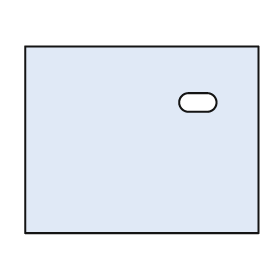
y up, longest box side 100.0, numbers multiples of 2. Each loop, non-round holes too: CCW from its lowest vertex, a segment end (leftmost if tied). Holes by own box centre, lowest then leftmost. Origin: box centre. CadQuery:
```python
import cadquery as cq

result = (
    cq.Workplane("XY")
    .moveTo(-50.0, -40.0)
    .lineTo(50.0, -40.0)
    .lineTo(50.0, 40.0)
    .lineTo(-50.0, 40.0)
    .close()
    .moveTo(20.0, 12.0)
    .lineTo(28.0, 12.0)
    .threePointArc((32.0, 16.0), (28.0, 20.0))
    .lineTo(20.0, 20.0)
    .threePointArc((16.0, 16.0), (20.0, 12.0))
    .close()
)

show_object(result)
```